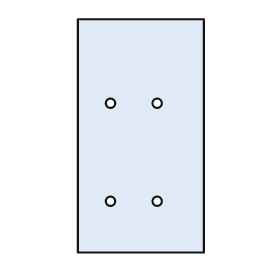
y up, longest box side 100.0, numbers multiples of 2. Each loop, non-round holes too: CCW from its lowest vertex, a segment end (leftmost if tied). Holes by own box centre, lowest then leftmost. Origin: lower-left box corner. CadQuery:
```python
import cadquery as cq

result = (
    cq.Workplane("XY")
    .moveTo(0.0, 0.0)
    .lineTo(54.0, 0.0)
    .lineTo(54.0, 100.0)
    .lineTo(0.0, 100.0)
    .close()
    .moveTo(14.0, 22.0)
    .circle(2.0)
    .moveTo(34.0, 22.0)
    .circle(2.0)
    .moveTo(14.0, 64.0)
    .circle(2.0)
    .moveTo(34.0, 64.0)
    .circle(2.0)
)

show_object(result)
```